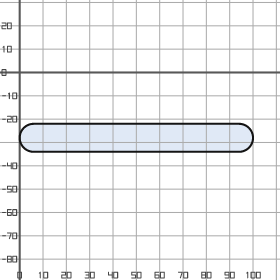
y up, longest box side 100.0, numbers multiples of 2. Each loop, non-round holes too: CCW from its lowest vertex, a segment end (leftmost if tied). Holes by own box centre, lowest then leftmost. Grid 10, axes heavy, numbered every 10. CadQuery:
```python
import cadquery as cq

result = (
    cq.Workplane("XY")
    .moveTo(6.0, -34.0)
    .lineTo(94.0, -34.0)
    .threePointArc((100.0, -28.0), (94.0, -22.0))
    .lineTo(6.0, -22.0)
    .threePointArc((0.0, -28.0), (6.0, -34.0))
    .close()
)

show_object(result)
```